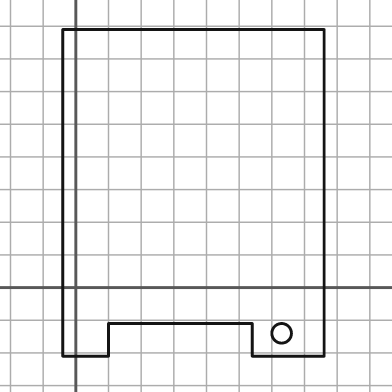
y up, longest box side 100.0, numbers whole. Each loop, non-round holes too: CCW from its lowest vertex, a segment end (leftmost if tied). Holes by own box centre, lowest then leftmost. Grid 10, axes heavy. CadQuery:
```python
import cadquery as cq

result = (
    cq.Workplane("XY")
    .moveTo(-4.0, -21.0)
    .lineTo(10.0, -21.0)
    .lineTo(10.0, -11.0)
    .lineTo(54.0, -11.0)
    .lineTo(54.0, -21.0)
    .lineTo(76.0, -21.0)
    .lineTo(76.0, 79.0)
    .lineTo(-4.0, 79.0)
    .close()
    .moveTo(63.0, -14.0)
    .circle(3.0)
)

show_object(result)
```